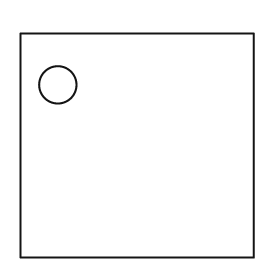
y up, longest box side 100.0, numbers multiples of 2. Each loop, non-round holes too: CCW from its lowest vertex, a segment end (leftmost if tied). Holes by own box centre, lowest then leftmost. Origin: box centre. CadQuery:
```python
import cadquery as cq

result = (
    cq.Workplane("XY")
    .moveTo(-50.0, -48.0)
    .lineTo(50.0, -48.0)
    .lineTo(50.0, 48.0)
    .lineTo(-50.0, 48.0)
    .close()
    .moveTo(-34.0, 26.0)
    .circle(8.0)
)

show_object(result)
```